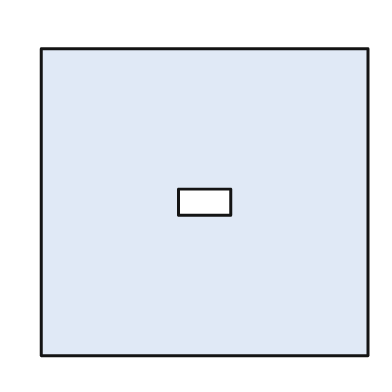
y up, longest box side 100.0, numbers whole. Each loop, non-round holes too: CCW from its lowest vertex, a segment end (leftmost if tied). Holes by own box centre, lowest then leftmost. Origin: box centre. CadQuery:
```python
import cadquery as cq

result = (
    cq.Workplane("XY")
    .moveTo(-50.0, -47.0)
    .lineTo(50.0, -47.0)
    .lineTo(50.0, 47.0)
    .lineTo(-50.0, 47.0)
    .close()
    .moveTo(-8.0, -4.0)
    .lineTo(8.0, -4.0)
    .lineTo(8.0, 4.0)
    .lineTo(-8.0, 4.0)
    .close()
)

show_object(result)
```